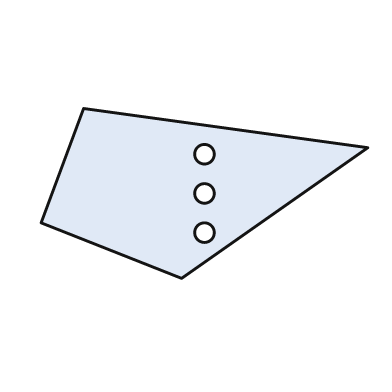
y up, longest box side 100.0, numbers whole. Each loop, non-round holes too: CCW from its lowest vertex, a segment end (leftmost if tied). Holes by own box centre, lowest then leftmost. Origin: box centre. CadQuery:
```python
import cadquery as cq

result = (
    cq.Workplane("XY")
    .moveTo(-7.0, -26.0)
    .lineTo(50.0, 14.0)
    .lineTo(-37.0, 26.0)
    .lineTo(-50.0, -9.0)
    .close()
    .moveTo(0.0, -12.0)
    .circle(3.0)
    .moveTo(0.0, 0.0)
    .circle(3.0)
    .moveTo(0.0, 12.0)
    .circle(3.0)
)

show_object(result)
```